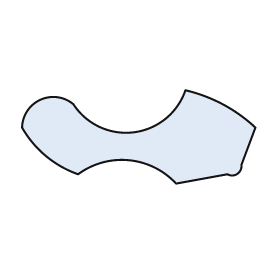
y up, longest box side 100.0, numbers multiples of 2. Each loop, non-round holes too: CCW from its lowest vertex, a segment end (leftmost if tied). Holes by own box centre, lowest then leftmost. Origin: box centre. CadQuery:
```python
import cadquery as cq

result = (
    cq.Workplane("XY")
    .moveTo(16.0, -20.0)
    .lineTo(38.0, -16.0)
    .threePointArc((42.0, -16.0), (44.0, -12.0))
    .lineTo(50.0, 4.0)
    .threePointArc((36.0, 14.0), (20.0, 20.0))
    .threePointArc((-2.0, 2.0), (-28.0, 14.0))
    .threePointArc((-42.0, 16.0), (-50.0, 4.0))
    .threePointArc((-40.0, -8.0), (-26.0, -16.0))
    .threePointArc((-4.0, -10.0), (16.0, -20.0))
    .close()
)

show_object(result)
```